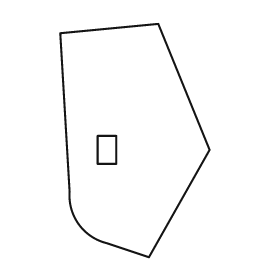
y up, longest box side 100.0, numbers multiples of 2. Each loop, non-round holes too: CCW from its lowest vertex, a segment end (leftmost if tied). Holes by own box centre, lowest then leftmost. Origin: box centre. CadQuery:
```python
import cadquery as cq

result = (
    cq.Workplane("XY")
    .moveTo(6.0, -50.0)
    .lineTo(32.0, -4.0)
    .lineTo(10.0, 50.0)
    .lineTo(-32.0, 46.0)
    .lineTo(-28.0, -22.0)
    .threePointArc((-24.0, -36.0), (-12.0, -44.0))
    .close()
    .moveTo(-16.0, -10.0)
    .lineTo(-8.0, -10.0)
    .lineTo(-8.0, 2.0)
    .lineTo(-16.0, 2.0)
    .close()
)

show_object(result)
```